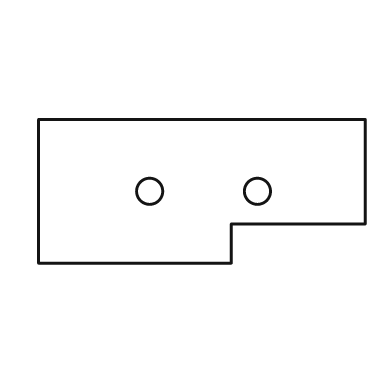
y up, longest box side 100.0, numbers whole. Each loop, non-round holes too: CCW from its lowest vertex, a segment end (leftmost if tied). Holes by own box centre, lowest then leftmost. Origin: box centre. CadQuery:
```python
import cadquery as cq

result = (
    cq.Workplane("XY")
    .moveTo(-50.0, -22.0)
    .lineTo(9.0, -22.0)
    .lineTo(9.0, -10.0)
    .lineTo(50.0, -10.0)
    .lineTo(50.0, 22.0)
    .lineTo(-50.0, 22.0)
    .close()
    .moveTo(-16.0, 0.0)
    .circle(4.0)
    .moveTo(17.0, 0.0)
    .circle(4.0)
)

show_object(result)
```